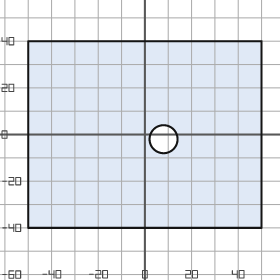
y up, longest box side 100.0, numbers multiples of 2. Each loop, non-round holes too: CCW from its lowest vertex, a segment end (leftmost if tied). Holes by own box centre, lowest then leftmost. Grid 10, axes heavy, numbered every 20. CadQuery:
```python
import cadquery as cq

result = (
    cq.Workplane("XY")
    .moveTo(-50.0, -40.0)
    .lineTo(50.0, -40.0)
    .lineTo(50.0, 40.0)
    .lineTo(-50.0, 40.0)
    .close()
    .moveTo(8.0, -2.0)
    .circle(6.0)
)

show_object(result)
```